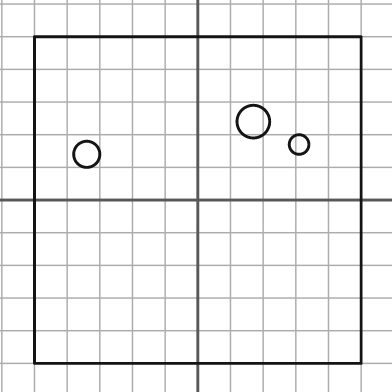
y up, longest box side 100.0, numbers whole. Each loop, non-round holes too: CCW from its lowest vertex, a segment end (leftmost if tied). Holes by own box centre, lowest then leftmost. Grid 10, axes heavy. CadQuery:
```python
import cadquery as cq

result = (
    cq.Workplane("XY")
    .moveTo(-50.0, -50.0)
    .lineTo(50.0, -50.0)
    .lineTo(50.0, 50.0)
    .lineTo(-50.0, 50.0)
    .close()
    .moveTo(-34.0, 14.0)
    .circle(4.0)
    .moveTo(31.0, 17.0)
    .circle(3.0)
    .moveTo(17.0, 24.0)
    .circle(5.0)
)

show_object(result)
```